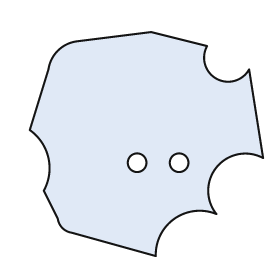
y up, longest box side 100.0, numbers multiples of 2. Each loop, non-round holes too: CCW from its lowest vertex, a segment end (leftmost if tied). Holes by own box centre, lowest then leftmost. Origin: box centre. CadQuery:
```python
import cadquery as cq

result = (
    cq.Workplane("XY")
    .moveTo(4.0, -48.0)
    .threePointArc((12.0, -32.0), (30.0, -30.0))
    .threePointArc((30.0, -10.0), (50.0, -6.0))
    .lineTo(44.0, 32.0)
    .threePointArc((30.0, 28.0), (26.0, 42.0))
    .lineTo(2.0, 48.0)
    .lineTo(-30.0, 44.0)
    .threePointArc((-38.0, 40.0), (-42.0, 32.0))
    .lineTo(-50.0, 6.0)
    .threePointArc((-42.0, -6.0), (-44.0, -20.0))
    .lineTo(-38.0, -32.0)
    .threePointArc((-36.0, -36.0), (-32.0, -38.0))
    .close()
    .moveTo(-4.0, -8.0)
    .circle(4.0)
    .moveTo(14.0, -8.0)
    .circle(4.0)
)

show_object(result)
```